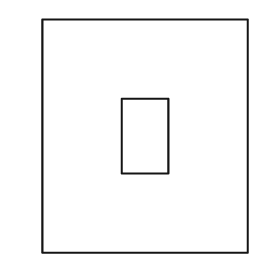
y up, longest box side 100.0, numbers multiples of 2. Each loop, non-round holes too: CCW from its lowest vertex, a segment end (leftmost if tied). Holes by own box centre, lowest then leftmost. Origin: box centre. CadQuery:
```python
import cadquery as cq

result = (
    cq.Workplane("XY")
    .moveTo(-44.0, -50.0)
    .lineTo(44.0, -50.0)
    .lineTo(44.0, 50.0)
    .lineTo(-44.0, 50.0)
    .close()
    .moveTo(-10.0, -16.0)
    .lineTo(10.0, -16.0)
    .lineTo(10.0, 16.0)
    .lineTo(-10.0, 16.0)
    .close()
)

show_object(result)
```